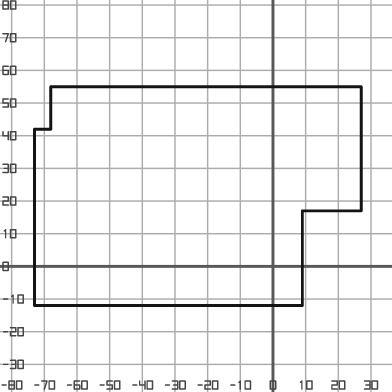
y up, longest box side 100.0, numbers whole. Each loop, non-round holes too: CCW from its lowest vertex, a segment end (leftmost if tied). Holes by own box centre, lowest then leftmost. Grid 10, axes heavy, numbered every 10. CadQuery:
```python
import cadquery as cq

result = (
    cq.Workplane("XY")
    .moveTo(-73.0, -12.0)
    .lineTo(9.0, -12.0)
    .lineTo(9.0, 17.0)
    .lineTo(27.0, 17.0)
    .lineTo(27.0, 55.0)
    .lineTo(-68.0, 55.0)
    .lineTo(-68.0, 42.0)
    .lineTo(-73.0, 42.0)
    .close()
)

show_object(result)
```